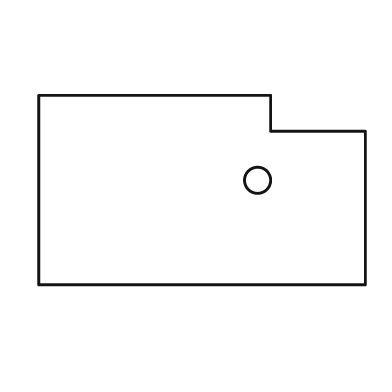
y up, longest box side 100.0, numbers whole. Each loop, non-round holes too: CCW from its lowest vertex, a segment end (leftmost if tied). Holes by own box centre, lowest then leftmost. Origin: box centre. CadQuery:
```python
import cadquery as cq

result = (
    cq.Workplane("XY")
    .moveTo(-50.0, -29.0)
    .lineTo(50.0, -29.0)
    .lineTo(50.0, 18.0)
    .lineTo(21.0, 18.0)
    .lineTo(21.0, 29.0)
    .lineTo(-50.0, 29.0)
    .close()
    .moveTo(17.0, 3.0)
    .circle(4.0)
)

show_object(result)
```